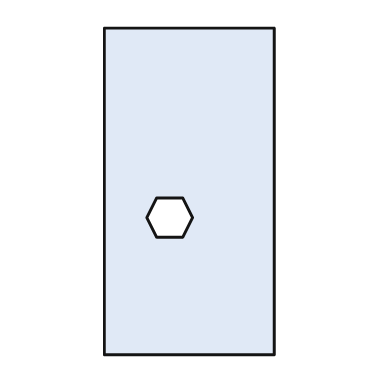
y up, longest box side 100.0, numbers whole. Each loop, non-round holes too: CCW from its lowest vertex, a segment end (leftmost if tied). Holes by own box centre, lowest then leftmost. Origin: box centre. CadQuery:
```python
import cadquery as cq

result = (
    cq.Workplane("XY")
    .moveTo(-26.0, -50.0)
    .lineTo(26.0, -50.0)
    .lineTo(26.0, 50.0)
    .lineTo(-26.0, 50.0)
    .close()
    .moveTo(-10.0, -14.0)
    .lineTo(-2.0, -14.0)
    .lineTo(1.0, -8.0)
    .lineTo(-2.0, -2.0)
    .lineTo(-10.0, -2.0)
    .lineTo(-13.0, -8.0)
    .close()
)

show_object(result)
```